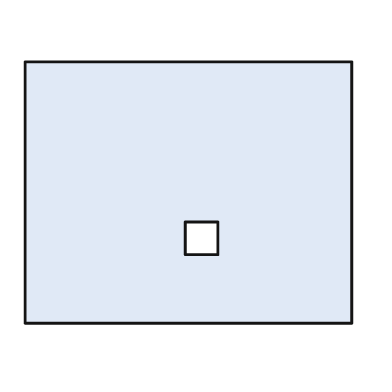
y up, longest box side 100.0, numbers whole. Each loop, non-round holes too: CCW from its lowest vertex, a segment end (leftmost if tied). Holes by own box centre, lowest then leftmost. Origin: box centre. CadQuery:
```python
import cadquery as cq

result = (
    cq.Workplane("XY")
    .moveTo(-50.0, -40.0)
    .lineTo(50.0, -40.0)
    .lineTo(50.0, 40.0)
    .lineTo(-50.0, 40.0)
    .close()
    .moveTo(-1.0, -19.0)
    .lineTo(9.0, -19.0)
    .lineTo(9.0, -9.0)
    .lineTo(-1.0, -9.0)
    .close()
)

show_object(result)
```